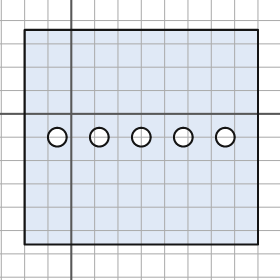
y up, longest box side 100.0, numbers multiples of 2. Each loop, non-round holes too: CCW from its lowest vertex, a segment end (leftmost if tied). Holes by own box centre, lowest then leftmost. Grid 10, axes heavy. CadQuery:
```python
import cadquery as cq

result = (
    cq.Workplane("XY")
    .moveTo(-20.0, -56.0)
    .lineTo(80.0, -56.0)
    .lineTo(80.0, 36.0)
    .lineTo(-20.0, 36.0)
    .close()
    .moveTo(-6.0, -10.0)
    .circle(4.0)
    .moveTo(12.0, -10.0)
    .circle(4.0)
    .moveTo(30.0, -10.0)
    .circle(4.0)
    .moveTo(48.0, -10.0)
    .circle(4.0)
    .moveTo(66.0, -10.0)
    .circle(4.0)
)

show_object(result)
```